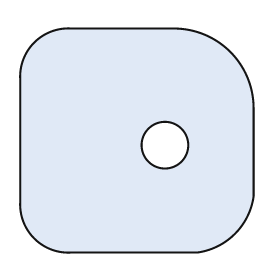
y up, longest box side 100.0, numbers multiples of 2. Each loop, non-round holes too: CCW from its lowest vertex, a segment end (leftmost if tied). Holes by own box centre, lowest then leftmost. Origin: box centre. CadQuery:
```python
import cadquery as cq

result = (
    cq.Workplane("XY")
    .moveTo(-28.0, -48.0)
    .lineTo(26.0, -48.0)
    .threePointArc((42.0, -40.0), (50.0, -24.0))
    .lineTo(50.0, 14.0)
    .threePointArc((40.0, 38.0), (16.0, 48.0))
    .lineTo(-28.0, 48.0)
    .threePointArc((-44.0, 42.0), (-50.0, 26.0))
    .lineTo(-50.0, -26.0)
    .threePointArc((-44.0, -42.0), (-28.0, -48.0))
    .close()
    .moveTo(12.0, -2.0)
    .circle(10.0)
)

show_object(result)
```